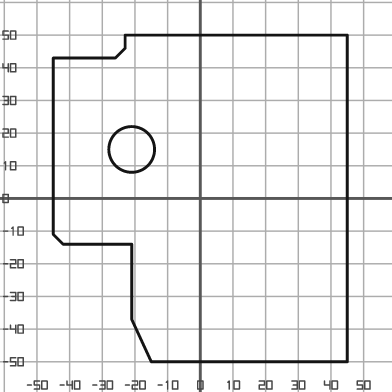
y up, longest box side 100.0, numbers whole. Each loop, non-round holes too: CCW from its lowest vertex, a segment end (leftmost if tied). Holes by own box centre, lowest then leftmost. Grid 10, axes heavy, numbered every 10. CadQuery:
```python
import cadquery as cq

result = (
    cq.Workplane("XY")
    .moveTo(-15.0, -50.0)
    .lineTo(45.0, -50.0)
    .lineTo(45.0, 50.0)
    .lineTo(-23.0, 50.0)
    .lineTo(-23.0, 46.0)
    .lineTo(-26.0, 43.0)
    .lineTo(-45.0, 43.0)
    .lineTo(-45.0, -11.0)
    .lineTo(-42.0, -14.0)
    .lineTo(-21.0, -14.0)
    .lineTo(-21.0, -37.0)
    .close()
    .moveTo(-21.0, 15.0)
    .circle(7.0)
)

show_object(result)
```